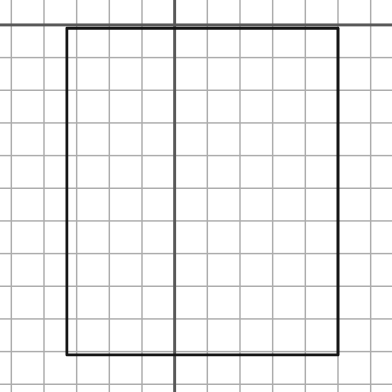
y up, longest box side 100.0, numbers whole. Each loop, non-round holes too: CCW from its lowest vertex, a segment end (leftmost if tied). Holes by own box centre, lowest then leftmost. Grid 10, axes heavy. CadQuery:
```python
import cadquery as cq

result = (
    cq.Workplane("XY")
    .moveTo(-33.0, -101.0)
    .lineTo(50.0, -101.0)
    .lineTo(50.0, -1.0)
    .lineTo(-33.0, -1.0)
    .close()
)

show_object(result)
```